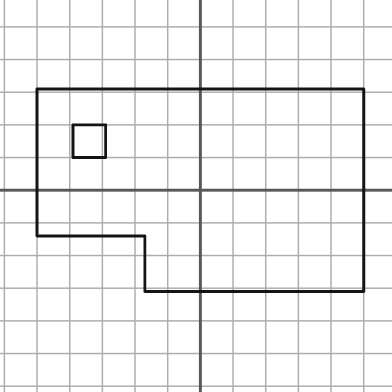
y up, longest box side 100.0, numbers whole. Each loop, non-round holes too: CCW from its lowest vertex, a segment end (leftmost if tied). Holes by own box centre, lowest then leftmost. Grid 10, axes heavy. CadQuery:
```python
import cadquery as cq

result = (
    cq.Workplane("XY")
    .moveTo(-17.0, -31.0)
    .lineTo(50.0, -31.0)
    .lineTo(50.0, 31.0)
    .lineTo(-50.0, 31.0)
    .lineTo(-50.0, -14.0)
    .lineTo(-17.0, -14.0)
    .close()
    .moveTo(-39.0, 10.0)
    .lineTo(-29.0, 10.0)
    .lineTo(-29.0, 20.0)
    .lineTo(-39.0, 20.0)
    .close()
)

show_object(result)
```